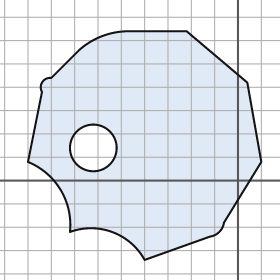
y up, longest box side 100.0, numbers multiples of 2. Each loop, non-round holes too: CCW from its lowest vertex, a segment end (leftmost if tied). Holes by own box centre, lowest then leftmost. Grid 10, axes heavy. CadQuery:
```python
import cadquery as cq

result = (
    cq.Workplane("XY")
    .moveTo(-40.0, -34.0)
    .lineTo(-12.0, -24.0)
    .threePointArc((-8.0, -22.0), (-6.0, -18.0))
    .lineTo(10.0, 8.0)
    .lineTo(4.0, 42.0)
    .lineTo(-22.0, 64.0)
    .lineTo(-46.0, 64.0)
    .threePointArc((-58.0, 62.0), (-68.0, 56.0))
    .lineTo(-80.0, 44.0)
    .threePointArc((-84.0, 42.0), (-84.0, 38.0))
    .lineTo(-90.0, 8.0)
    .threePointArc((-76.0, -4.0), (-72.0, -22.0))
    .threePointArc((-54.0, -22.0), (-40.0, -34.0))
    .close()
    .moveTo(-62.0, 14.0)
    .circle(10.0)
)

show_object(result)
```